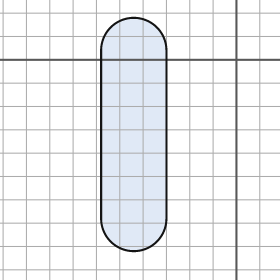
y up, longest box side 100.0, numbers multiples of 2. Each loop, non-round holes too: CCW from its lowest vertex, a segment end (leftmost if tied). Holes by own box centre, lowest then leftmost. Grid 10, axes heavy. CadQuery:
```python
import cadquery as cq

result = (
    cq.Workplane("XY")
    .moveTo(-58.0, -68.0)
    .threePointArc((-44.0, -82.0), (-30.0, -68.0))
    .lineTo(-30.0, 4.0)
    .threePointArc((-44.0, 18.0), (-58.0, 4.0))
    .close()
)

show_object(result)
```